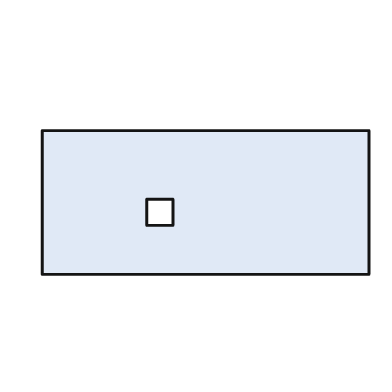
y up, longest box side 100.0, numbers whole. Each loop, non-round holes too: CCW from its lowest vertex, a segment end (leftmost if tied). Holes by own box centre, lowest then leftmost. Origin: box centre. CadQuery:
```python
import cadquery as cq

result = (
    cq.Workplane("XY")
    .moveTo(-50.0, -22.0)
    .lineTo(50.0, -22.0)
    .lineTo(50.0, 22.0)
    .lineTo(-50.0, 22.0)
    .close()
    .moveTo(-18.0, -7.0)
    .lineTo(-10.0, -7.0)
    .lineTo(-10.0, 1.0)
    .lineTo(-18.0, 1.0)
    .close()
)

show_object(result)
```